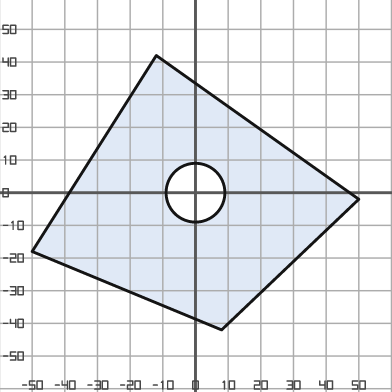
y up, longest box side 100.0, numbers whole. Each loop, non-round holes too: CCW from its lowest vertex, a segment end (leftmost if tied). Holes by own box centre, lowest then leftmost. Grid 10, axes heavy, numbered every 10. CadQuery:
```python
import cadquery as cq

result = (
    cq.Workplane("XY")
    .moveTo(8.0, -42.0)
    .lineTo(50.0, -2.0)
    .lineTo(-12.0, 42.0)
    .lineTo(-50.0, -18.0)
    .close()
    .moveTo(0.0, 0.0)
    .circle(9.0)
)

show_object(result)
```